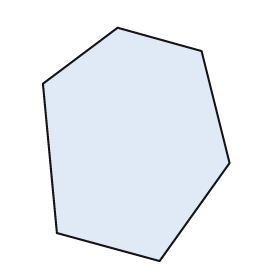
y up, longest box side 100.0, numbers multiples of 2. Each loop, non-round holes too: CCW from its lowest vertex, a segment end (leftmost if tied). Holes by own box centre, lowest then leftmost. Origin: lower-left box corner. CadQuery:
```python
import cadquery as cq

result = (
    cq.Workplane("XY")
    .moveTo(50.0, 0.0)
    .lineTo(80.0, 42.0)
    .lineTo(68.0, 90.0)
    .lineTo(32.0, 100.0)
    .lineTo(0.0, 76.0)
    .lineTo(6.0, 12.0)
    .close()
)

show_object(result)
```